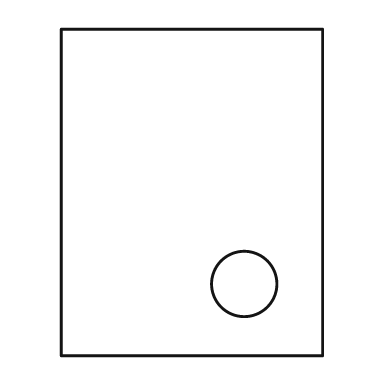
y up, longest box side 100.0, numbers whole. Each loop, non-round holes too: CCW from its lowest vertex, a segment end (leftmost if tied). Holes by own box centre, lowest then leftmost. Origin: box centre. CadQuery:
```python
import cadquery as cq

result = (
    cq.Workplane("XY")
    .moveTo(-40.0, -50.0)
    .lineTo(40.0, -50.0)
    .lineTo(40.0, 50.0)
    .lineTo(-40.0, 50.0)
    .close()
    .moveTo(16.0, -28.0)
    .circle(10.0)
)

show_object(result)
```